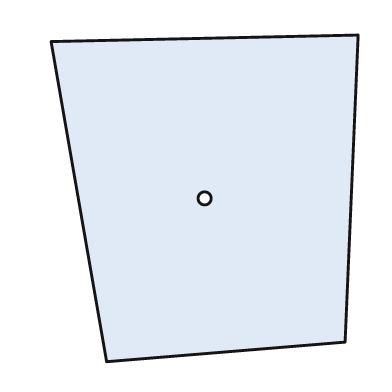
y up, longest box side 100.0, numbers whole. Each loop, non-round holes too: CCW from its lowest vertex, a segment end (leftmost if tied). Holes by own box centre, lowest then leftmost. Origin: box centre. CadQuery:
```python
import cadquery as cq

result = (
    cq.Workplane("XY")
    .moveTo(-30.0, -50.0)
    .lineTo(43.0, -44.0)
    .lineTo(47.0, 50.0)
    .lineTo(-47.0, 48.0)
    .close()
    .moveTo(0.0, 0.0)
    .circle(2.0)
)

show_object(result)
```